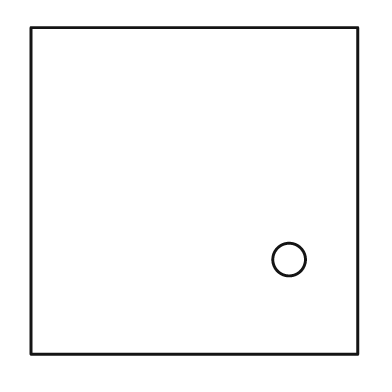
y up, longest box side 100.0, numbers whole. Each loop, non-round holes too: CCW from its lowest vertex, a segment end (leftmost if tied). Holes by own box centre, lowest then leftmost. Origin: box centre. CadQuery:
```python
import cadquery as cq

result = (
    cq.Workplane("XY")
    .moveTo(-50.0, -50.0)
    .lineTo(50.0, -50.0)
    .lineTo(50.0, 50.0)
    .lineTo(-50.0, 50.0)
    .close()
    .moveTo(29.0, -21.0)
    .circle(5.0)
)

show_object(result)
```